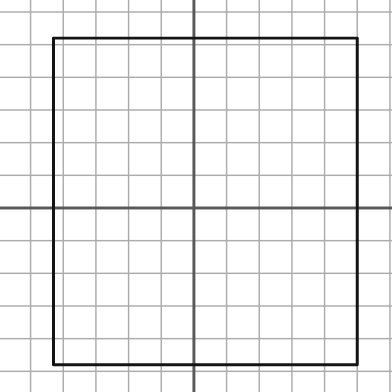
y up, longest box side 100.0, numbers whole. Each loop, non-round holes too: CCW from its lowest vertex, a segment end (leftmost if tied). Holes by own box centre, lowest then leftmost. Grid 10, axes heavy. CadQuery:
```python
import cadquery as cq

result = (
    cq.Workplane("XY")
    .moveTo(-43.0, -48.0)
    .lineTo(50.0, -48.0)
    .lineTo(50.0, 52.0)
    .lineTo(-43.0, 52.0)
    .close()
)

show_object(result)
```